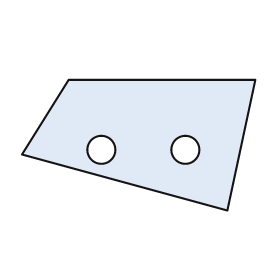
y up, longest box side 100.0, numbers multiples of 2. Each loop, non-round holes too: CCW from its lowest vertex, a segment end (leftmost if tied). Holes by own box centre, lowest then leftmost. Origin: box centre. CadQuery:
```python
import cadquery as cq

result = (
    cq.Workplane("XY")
    .moveTo(38.0, -28.0)
    .lineTo(50.0, 28.0)
    .lineTo(-30.0, 28.0)
    .lineTo(-50.0, -4.0)
    .close()
    .moveTo(-16.0, -2.0)
    .circle(6.0)
    .moveTo(20.0, -2.0)
    .circle(6.0)
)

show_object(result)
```